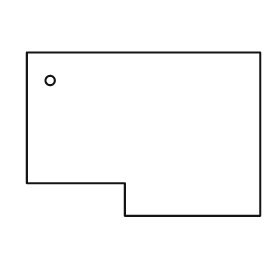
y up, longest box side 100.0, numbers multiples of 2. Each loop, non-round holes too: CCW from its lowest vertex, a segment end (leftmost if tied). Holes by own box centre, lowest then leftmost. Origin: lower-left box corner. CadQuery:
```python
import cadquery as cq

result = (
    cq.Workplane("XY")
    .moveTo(42.0, 0.0)
    .lineTo(100.0, 0.0)
    .lineTo(100.0, 70.0)
    .lineTo(0.0, 70.0)
    .lineTo(0.0, 14.0)
    .lineTo(42.0, 14.0)
    .close()
    .moveTo(10.0, 58.0)
    .circle(2.0)
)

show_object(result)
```